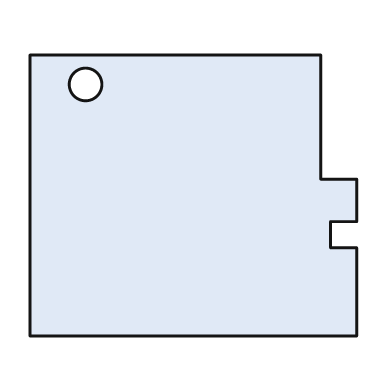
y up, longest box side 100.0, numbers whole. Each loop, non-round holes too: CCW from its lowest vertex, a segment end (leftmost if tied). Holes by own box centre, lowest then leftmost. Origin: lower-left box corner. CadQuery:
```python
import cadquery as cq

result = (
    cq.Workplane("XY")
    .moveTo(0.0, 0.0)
    .lineTo(100.0, 0.0)
    .lineTo(100.0, 27.0)
    .lineTo(92.0, 27.0)
    .lineTo(92.0, 35.0)
    .lineTo(100.0, 35.0)
    .lineTo(100.0, 48.0)
    .lineTo(89.0, 48.0)
    .lineTo(89.0, 86.0)
    .lineTo(0.0, 86.0)
    .close()
    .moveTo(17.0, 77.0)
    .circle(5.0)
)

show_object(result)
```